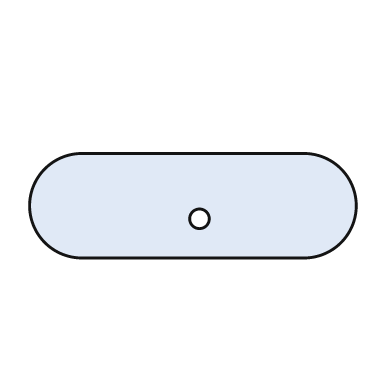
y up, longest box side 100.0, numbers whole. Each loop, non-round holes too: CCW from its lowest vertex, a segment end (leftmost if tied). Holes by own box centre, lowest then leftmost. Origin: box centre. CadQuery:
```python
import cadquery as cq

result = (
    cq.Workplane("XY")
    .moveTo(-34.0, -16.0)
    .lineTo(34.0, -16.0)
    .threePointArc((50.0, 0.0), (34.0, 16.0))
    .lineTo(-34.0, 16.0)
    .threePointArc((-50.0, 0.0), (-34.0, -16.0))
    .close()
    .moveTo(2.0, -4.0)
    .circle(3.0)
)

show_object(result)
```